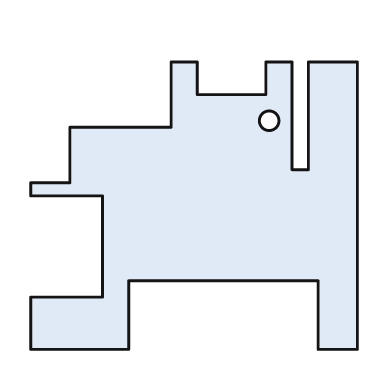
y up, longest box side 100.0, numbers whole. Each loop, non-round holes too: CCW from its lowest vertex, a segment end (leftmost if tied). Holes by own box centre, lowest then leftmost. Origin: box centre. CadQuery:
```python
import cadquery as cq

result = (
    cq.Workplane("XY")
    .moveTo(-50.0, -44.0)
    .lineTo(-20.0, -44.0)
    .lineTo(-20.0, -23.0)
    .lineTo(38.0, -23.0)
    .lineTo(38.0, -44.0)
    .lineTo(50.0, -44.0)
    .lineTo(50.0, 44.0)
    .lineTo(35.0, 44.0)
    .lineTo(35.0, 11.0)
    .lineTo(30.0, 11.0)
    .lineTo(30.0, 44.0)
    .lineTo(22.0, 44.0)
    .lineTo(22.0, 34.0)
    .lineTo(1.0, 34.0)
    .lineTo(1.0, 44.0)
    .lineTo(-7.0, 44.0)
    .lineTo(-7.0, 24.0)
    .lineTo(-38.0, 24.0)
    .lineTo(-38.0, 7.0)
    .lineTo(-50.0, 7.0)
    .lineTo(-50.0, 3.0)
    .lineTo(-28.0, 3.0)
    .lineTo(-28.0, -28.0)
    .lineTo(-50.0, -28.0)
    .close()
    .moveTo(23.0, 26.0)
    .circle(3.0)
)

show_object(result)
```